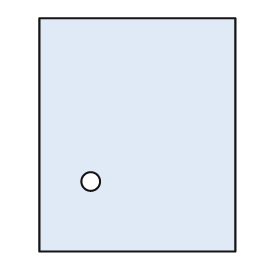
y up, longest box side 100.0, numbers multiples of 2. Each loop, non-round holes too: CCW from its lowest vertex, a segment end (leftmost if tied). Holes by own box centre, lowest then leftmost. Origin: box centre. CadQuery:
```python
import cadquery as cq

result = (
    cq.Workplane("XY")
    .moveTo(-42.0, -50.0)
    .lineTo(42.0, -50.0)
    .lineTo(42.0, 50.0)
    .lineTo(-42.0, 50.0)
    .close()
    .moveTo(-20.0, -20.0)
    .circle(4.0)
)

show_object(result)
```